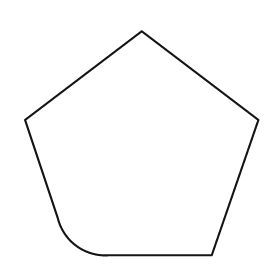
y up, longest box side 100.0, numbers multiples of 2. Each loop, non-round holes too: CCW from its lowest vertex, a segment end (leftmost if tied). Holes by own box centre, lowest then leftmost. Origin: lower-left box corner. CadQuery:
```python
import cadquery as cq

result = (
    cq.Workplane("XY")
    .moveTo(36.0, 0.0)
    .lineTo(80.0, 0.0)
    .lineTo(100.0, 58.0)
    .lineTo(50.0, 96.0)
    .lineTo(0.0, 58.0)
    .lineTo(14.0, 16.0)
    .threePointArc((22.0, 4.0), (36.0, 0.0))
    .close()
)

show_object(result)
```